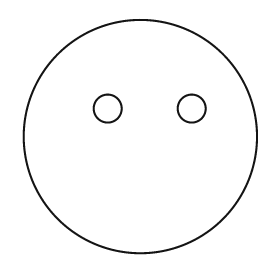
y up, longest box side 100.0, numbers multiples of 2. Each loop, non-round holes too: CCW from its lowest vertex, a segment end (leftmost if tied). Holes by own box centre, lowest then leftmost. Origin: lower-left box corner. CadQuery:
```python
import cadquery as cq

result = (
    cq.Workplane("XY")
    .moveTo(50.0, 50.0)
    .circle(50.0)
    .moveTo(36.0, 62.0)
    .circle(6.0)
    .moveTo(72.0, 62.0)
    .circle(6.0)
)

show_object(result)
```